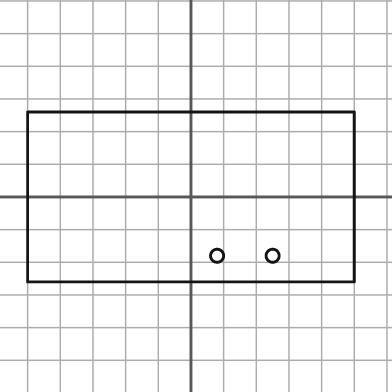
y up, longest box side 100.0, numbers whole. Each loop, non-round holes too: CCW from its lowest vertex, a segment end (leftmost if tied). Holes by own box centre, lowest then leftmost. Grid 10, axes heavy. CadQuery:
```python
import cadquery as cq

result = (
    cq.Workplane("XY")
    .moveTo(-50.0, -26.0)
    .lineTo(50.0, -26.0)
    .lineTo(50.0, 26.0)
    .lineTo(-50.0, 26.0)
    .close()
    .moveTo(8.0, -18.0)
    .circle(2.0)
    .moveTo(25.0, -18.0)
    .circle(2.0)
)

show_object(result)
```